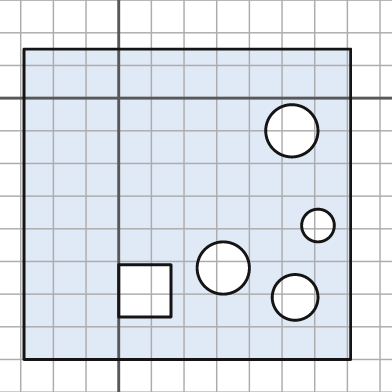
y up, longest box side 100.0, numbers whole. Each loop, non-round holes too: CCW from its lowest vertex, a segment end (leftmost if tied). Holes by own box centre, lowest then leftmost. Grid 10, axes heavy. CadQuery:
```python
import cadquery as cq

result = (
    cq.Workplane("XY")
    .moveTo(-29.0, -80.0)
    .lineTo(71.0, -80.0)
    .lineTo(71.0, 15.0)
    .lineTo(-29.0, 15.0)
    .close()
    .moveTo(54.0, -61.0)
    .circle(7.0)
    .moveTo(0.0, -67.0)
    .lineTo(16.0, -67.0)
    .lineTo(16.0, -51.0)
    .lineTo(0.0, -51.0)
    .close()
    .moveTo(32.0, -52.0)
    .circle(8.0)
    .moveTo(61.0, -39.0)
    .circle(5.0)
    .moveTo(53.0, -10.0)
    .circle(8.0)
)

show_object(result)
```